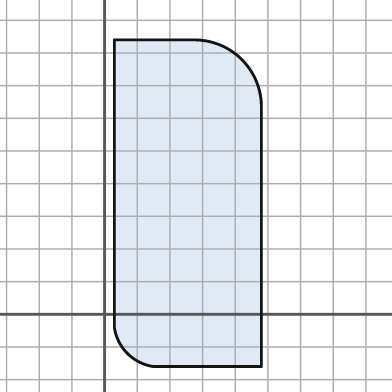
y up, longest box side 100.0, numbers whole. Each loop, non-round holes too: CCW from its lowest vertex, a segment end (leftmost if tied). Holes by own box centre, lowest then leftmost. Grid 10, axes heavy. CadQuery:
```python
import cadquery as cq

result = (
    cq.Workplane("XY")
    .moveTo(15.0, -16.0)
    .lineTo(48.0, -16.0)
    .lineTo(48.0, 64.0)
    .threePointArc((42.0, 78.0), (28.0, 84.0))
    .lineTo(3.0, 84.0)
    .lineTo(3.0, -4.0)
    .threePointArc((7.0, -12.0), (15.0, -16.0))
    .close()
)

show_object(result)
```